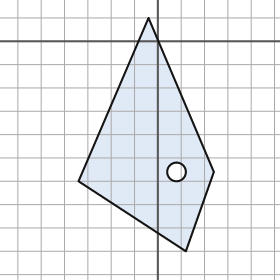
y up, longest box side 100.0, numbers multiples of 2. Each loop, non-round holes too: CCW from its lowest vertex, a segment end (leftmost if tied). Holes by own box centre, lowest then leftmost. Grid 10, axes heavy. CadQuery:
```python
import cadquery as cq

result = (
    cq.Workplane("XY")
    .moveTo(12.0, -90.0)
    .lineTo(24.0, -56.0)
    .lineTo(-4.0, 10.0)
    .lineTo(-34.0, -60.0)
    .close()
    .moveTo(8.0, -56.0)
    .circle(4.0)
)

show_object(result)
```